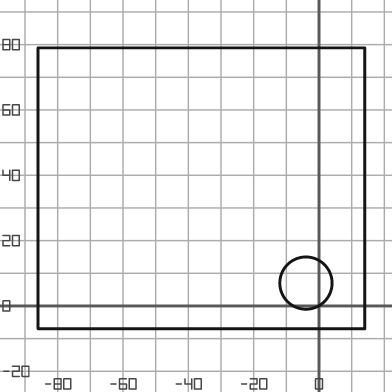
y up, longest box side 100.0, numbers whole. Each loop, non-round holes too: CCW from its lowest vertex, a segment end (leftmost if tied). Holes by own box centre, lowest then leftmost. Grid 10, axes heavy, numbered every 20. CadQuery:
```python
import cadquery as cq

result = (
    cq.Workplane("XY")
    .moveTo(-86.0, -7.0)
    .lineTo(14.0, -7.0)
    .lineTo(14.0, 79.0)
    .lineTo(-86.0, 79.0)
    .close()
    .moveTo(-4.0, 7.0)
    .circle(8.0)
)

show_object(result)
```